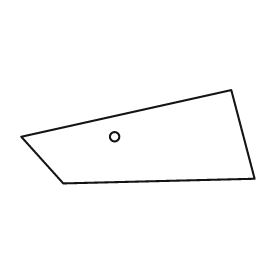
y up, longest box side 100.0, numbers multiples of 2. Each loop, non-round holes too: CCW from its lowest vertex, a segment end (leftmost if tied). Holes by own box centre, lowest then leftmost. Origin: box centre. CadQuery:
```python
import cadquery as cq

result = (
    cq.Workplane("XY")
    .moveTo(-32.0, -20.0)
    .lineTo(50.0, -18.0)
    .lineTo(40.0, 20.0)
    .lineTo(-50.0, 0.0)
    .close()
    .moveTo(-10.0, 0.0)
    .circle(2.0)
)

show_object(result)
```